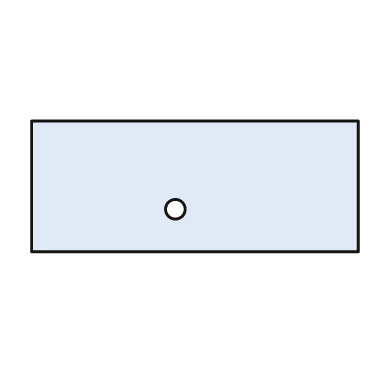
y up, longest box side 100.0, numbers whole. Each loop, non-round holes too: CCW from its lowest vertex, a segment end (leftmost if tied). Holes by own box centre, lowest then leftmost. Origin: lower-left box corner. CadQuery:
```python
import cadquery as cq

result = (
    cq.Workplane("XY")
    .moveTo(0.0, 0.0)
    .lineTo(100.0, 0.0)
    .lineTo(100.0, 40.0)
    .lineTo(0.0, 40.0)
    .close()
    .moveTo(44.0, 13.0)
    .circle(3.0)
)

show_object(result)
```